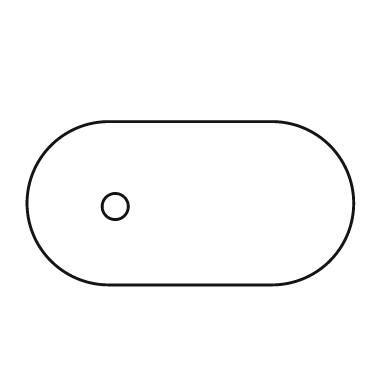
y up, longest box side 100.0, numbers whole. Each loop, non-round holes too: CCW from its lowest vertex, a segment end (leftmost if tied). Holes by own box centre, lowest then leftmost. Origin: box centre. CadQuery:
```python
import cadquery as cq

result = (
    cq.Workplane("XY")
    .moveTo(-25.0, -25.0)
    .lineTo(25.0, -25.0)
    .threePointArc((50.0, 0.0), (25.0, 25.0))
    .lineTo(-25.0, 25.0)
    .threePointArc((-50.0, 0.0), (-25.0, -25.0))
    .close()
    .moveTo(-23.0, -1.0)
    .circle(4.0)
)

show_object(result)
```